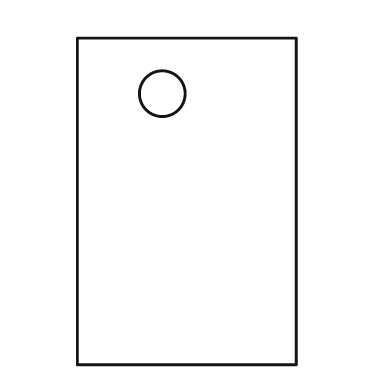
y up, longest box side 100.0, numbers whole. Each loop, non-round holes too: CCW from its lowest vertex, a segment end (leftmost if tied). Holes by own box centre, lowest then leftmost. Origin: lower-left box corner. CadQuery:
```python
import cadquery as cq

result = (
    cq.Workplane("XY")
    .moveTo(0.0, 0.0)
    .lineTo(67.0, 0.0)
    .lineTo(67.0, 100.0)
    .lineTo(0.0, 100.0)
    .close()
    .moveTo(26.0, 83.0)
    .circle(7.0)
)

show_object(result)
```